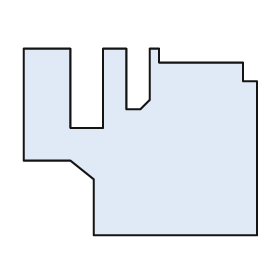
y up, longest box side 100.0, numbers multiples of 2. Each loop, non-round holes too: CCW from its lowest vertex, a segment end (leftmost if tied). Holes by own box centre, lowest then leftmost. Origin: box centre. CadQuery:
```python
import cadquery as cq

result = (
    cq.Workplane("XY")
    .moveTo(-20.0, -40.0)
    .lineTo(50.0, -40.0)
    .lineTo(50.0, 26.0)
    .lineTo(44.0, 26.0)
    .lineTo(44.0, 34.0)
    .lineTo(8.0, 34.0)
    .lineTo(8.0, 40.0)
    .lineTo(4.0, 40.0)
    .lineTo(4.0, 18.0)
    .lineTo(0.0, 14.0)
    .lineTo(-6.0, 14.0)
    .lineTo(-6.0, 40.0)
    .lineTo(-16.0, 40.0)
    .lineTo(-16.0, 6.0)
    .lineTo(-30.0, 6.0)
    .lineTo(-30.0, 40.0)
    .lineTo(-50.0, 40.0)
    .lineTo(-50.0, -8.0)
    .lineTo(-30.0, -8.0)
    .lineTo(-20.0, -16.0)
    .close()
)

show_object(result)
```